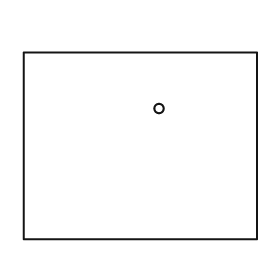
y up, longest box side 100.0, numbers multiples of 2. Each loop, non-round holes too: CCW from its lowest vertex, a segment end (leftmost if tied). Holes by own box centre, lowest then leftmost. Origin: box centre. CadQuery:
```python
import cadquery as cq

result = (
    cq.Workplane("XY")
    .moveTo(-50.0, -40.0)
    .lineTo(50.0, -40.0)
    .lineTo(50.0, 40.0)
    .lineTo(-50.0, 40.0)
    .close()
    .moveTo(8.0, 16.0)
    .circle(2.0)
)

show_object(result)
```